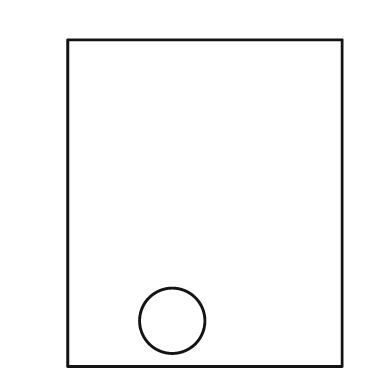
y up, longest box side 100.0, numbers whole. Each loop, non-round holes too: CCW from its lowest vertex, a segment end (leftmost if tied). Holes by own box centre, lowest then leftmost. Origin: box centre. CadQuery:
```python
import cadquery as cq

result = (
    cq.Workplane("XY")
    .moveTo(-42.0, -50.0)
    .lineTo(42.0, -50.0)
    .lineTo(42.0, 50.0)
    .lineTo(-42.0, 50.0)
    .close()
    .moveTo(-10.0, -36.0)
    .circle(10.0)
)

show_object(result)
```